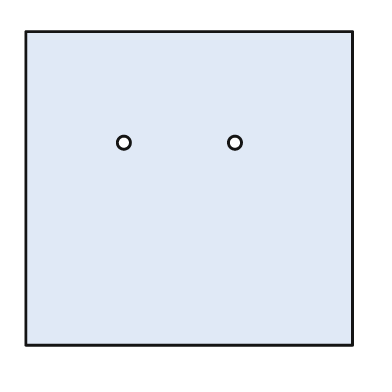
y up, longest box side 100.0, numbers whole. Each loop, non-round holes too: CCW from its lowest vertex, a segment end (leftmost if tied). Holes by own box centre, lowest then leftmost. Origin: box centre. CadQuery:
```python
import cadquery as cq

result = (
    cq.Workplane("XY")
    .moveTo(-50.0, -48.0)
    .lineTo(50.0, -48.0)
    .lineTo(50.0, 48.0)
    .lineTo(-50.0, 48.0)
    .close()
    .moveTo(-20.0, 14.0)
    .circle(2.0)
    .moveTo(14.0, 14.0)
    .circle(2.0)
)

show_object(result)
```